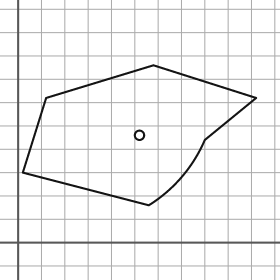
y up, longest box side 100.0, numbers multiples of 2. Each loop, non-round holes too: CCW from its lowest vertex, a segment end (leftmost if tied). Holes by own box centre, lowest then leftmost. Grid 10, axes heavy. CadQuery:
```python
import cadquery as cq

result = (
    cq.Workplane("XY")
    .moveTo(56.0, 16.0)
    .threePointArc((70.0, 28.0), (80.0, 44.0))
    .lineTo(102.0, 62.0)
    .lineTo(58.0, 76.0)
    .lineTo(12.0, 62.0)
    .lineTo(2.0, 30.0)
    .close()
    .moveTo(52.0, 46.0)
    .circle(2.0)
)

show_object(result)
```